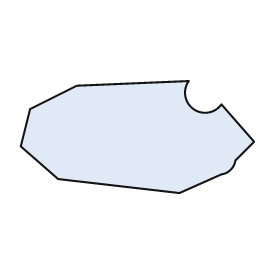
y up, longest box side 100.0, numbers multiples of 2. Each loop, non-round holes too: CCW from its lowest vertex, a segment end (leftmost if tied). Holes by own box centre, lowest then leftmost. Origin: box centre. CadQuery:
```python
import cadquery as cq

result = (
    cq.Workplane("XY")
    .moveTo(18.0, -24.0)
    .lineTo(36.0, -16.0)
    .threePointArc((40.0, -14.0), (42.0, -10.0))
    .lineTo(50.0, -2.0)
    .lineTo(36.0, 14.0)
    .threePointArc((24.0, 12.0), (22.0, 24.0))
    .lineTo(-26.0, 22.0)
    .lineTo(-46.0, 12.0)
    .lineTo(-50.0, -4.0)
    .lineTo(-34.0, -18.0)
    .close()
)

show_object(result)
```